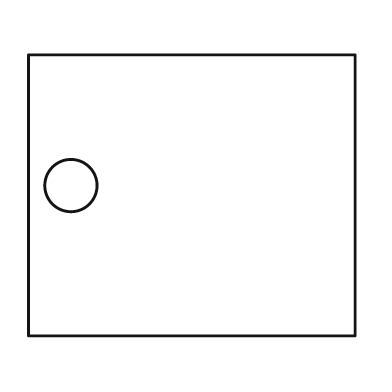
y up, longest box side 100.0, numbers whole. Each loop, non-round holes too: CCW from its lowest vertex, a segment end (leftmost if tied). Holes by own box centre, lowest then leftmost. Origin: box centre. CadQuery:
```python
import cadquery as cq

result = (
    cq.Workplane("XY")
    .moveTo(-50.0, -43.0)
    .lineTo(50.0, -43.0)
    .lineTo(50.0, 43.0)
    .lineTo(-50.0, 43.0)
    .close()
    .moveTo(-37.0, 3.0)
    .circle(8.0)
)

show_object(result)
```